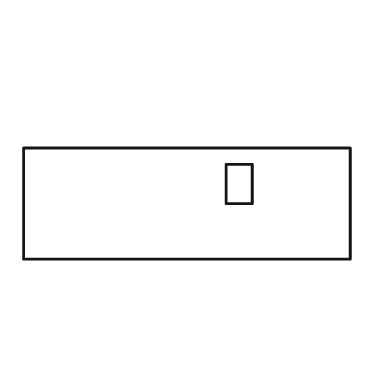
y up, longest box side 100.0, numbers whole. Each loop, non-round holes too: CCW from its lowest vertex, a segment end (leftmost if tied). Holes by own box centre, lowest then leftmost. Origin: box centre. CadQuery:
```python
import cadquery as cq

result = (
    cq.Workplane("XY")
    .moveTo(-50.0, -17.0)
    .lineTo(50.0, -17.0)
    .lineTo(50.0, 17.0)
    .lineTo(-50.0, 17.0)
    .close()
    .moveTo(12.0, 0.0)
    .lineTo(20.0, 0.0)
    .lineTo(20.0, 12.0)
    .lineTo(12.0, 12.0)
    .close()
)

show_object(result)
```